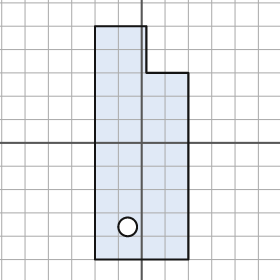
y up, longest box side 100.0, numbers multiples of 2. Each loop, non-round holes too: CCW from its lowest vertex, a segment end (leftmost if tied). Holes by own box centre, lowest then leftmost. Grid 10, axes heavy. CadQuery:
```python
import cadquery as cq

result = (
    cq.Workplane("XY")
    .moveTo(-20.0, -50.0)
    .lineTo(20.0, -50.0)
    .lineTo(20.0, 30.0)
    .lineTo(2.0, 30.0)
    .lineTo(2.0, 50.0)
    .lineTo(-20.0, 50.0)
    .close()
    .moveTo(-6.0, -36.0)
    .circle(4.0)
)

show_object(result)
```